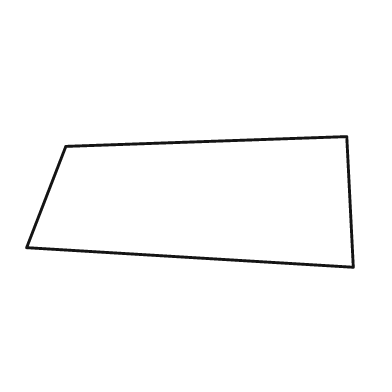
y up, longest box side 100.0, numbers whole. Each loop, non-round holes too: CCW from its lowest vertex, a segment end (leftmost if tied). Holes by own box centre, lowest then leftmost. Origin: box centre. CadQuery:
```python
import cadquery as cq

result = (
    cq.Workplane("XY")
    .moveTo(50.0, -20.0)
    .lineTo(48.0, 20.0)
    .lineTo(-38.0, 17.0)
    .lineTo(-50.0, -14.0)
    .close()
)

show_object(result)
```